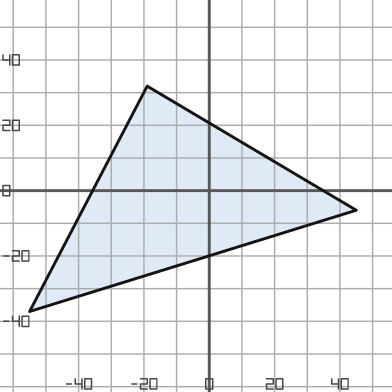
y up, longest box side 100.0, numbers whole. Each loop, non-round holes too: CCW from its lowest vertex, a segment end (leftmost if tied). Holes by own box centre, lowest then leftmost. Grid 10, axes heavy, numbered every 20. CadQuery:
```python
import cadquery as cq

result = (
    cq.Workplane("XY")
    .moveTo(-55.0, -37.0)
    .lineTo(45.0, -6.0)
    .lineTo(-19.0, 32.0)
    .close()
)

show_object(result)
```